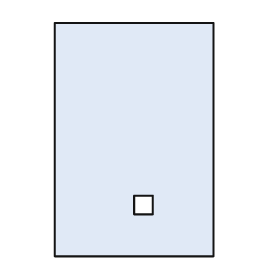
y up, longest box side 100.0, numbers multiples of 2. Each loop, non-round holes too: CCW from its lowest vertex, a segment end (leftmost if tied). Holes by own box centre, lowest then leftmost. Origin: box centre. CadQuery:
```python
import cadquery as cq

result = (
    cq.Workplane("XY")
    .moveTo(-34.0, -50.0)
    .lineTo(34.0, -50.0)
    .lineTo(34.0, 50.0)
    .lineTo(-34.0, 50.0)
    .close()
    .moveTo(0.0, -32.0)
    .lineTo(8.0, -32.0)
    .lineTo(8.0, -24.0)
    .lineTo(0.0, -24.0)
    .close()
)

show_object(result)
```